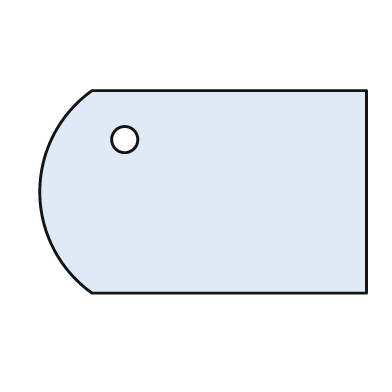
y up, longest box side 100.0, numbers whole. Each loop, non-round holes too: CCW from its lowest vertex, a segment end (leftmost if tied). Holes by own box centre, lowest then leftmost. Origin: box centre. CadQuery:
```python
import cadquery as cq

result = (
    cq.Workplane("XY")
    .moveTo(-34.0, -31.0)
    .lineTo(50.0, -31.0)
    .lineTo(50.0, 31.0)
    .lineTo(-34.0, 31.0)
    .threePointArc((-50.0, 0.0), (-34.0, -31.0))
    .close()
    .moveTo(-24.0, 16.0)
    .circle(4.0)
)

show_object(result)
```